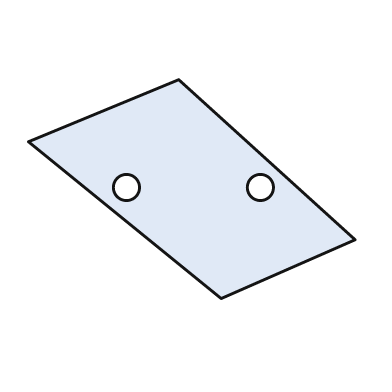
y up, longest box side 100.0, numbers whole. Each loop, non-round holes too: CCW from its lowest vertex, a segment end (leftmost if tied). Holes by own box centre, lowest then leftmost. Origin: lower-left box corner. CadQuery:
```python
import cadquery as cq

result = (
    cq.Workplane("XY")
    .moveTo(59.0, 0.0)
    .lineTo(100.0, 18.0)
    .lineTo(46.0, 67.0)
    .lineTo(0.0, 48.0)
    .close()
    .moveTo(30.0, 34.0)
    .circle(4.0)
    .moveTo(71.0, 34.0)
    .circle(4.0)
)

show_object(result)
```